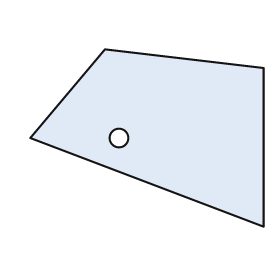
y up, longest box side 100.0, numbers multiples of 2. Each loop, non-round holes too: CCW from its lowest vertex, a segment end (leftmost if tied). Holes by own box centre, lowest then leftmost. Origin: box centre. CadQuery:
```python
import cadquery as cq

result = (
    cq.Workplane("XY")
    .moveTo(50.0, -38.0)
    .lineTo(50.0, 30.0)
    .lineTo(-18.0, 38.0)
    .lineTo(-50.0, 0.0)
    .close()
    .moveTo(-12.0, 0.0)
    .circle(4.0)
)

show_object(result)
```